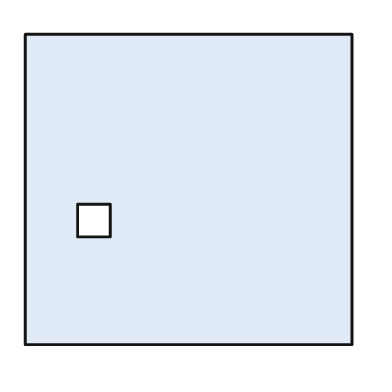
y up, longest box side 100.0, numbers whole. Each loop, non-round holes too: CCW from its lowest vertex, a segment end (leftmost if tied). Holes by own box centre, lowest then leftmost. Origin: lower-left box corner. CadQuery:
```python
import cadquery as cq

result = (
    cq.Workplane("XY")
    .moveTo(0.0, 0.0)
    .lineTo(100.0, 0.0)
    .lineTo(100.0, 95.0)
    .lineTo(0.0, 95.0)
    .close()
    .moveTo(16.0, 33.0)
    .lineTo(26.0, 33.0)
    .lineTo(26.0, 43.0)
    .lineTo(16.0, 43.0)
    .close()
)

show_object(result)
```